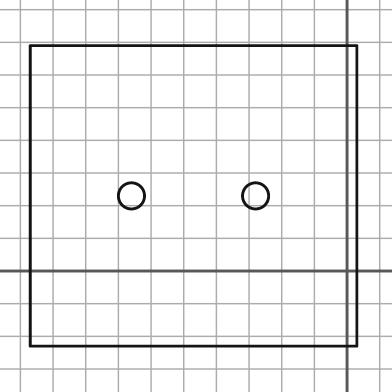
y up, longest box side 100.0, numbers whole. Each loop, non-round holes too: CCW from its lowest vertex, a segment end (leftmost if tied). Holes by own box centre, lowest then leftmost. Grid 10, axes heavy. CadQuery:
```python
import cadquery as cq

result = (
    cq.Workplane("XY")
    .moveTo(-97.0, -23.0)
    .lineTo(3.0, -23.0)
    .lineTo(3.0, 69.0)
    .lineTo(-97.0, 69.0)
    .close()
    .moveTo(-66.0, 23.0)
    .circle(4.0)
    .moveTo(-28.0, 23.0)
    .circle(4.0)
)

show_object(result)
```